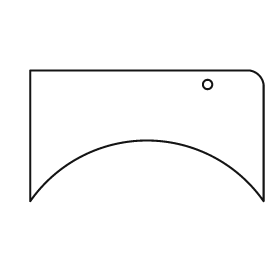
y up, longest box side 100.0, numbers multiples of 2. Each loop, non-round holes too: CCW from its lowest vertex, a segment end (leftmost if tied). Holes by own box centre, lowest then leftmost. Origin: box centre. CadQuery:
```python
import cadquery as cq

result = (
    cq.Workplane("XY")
    .moveTo(-50.0, -28.0)
    .threePointArc((0.0, -2.0), (50.0, -28.0))
    .lineTo(50.0, 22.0)
    .threePointArc((48.0, 26.0), (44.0, 28.0))
    .lineTo(-50.0, 28.0)
    .close()
    .moveTo(26.0, 22.0)
    .circle(2.0)
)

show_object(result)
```